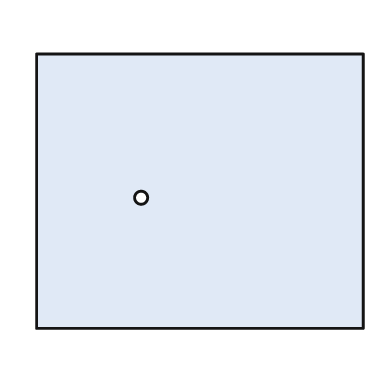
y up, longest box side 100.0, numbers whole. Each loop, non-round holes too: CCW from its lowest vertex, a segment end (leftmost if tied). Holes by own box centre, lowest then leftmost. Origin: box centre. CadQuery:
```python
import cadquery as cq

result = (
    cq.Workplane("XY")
    .moveTo(-50.0, -42.0)
    .lineTo(50.0, -42.0)
    .lineTo(50.0, 42.0)
    .lineTo(-50.0, 42.0)
    .close()
    .moveTo(-18.0, -2.0)
    .circle(2.0)
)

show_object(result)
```